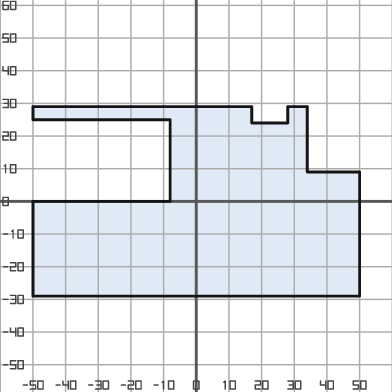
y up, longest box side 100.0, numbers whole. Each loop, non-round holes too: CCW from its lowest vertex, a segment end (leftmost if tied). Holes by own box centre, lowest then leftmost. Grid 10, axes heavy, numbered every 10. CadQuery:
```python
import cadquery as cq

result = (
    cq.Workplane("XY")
    .moveTo(-50.0, -29.0)
    .lineTo(50.0, -29.0)
    .lineTo(50.0, 9.0)
    .lineTo(34.0, 9.0)
    .lineTo(34.0, 29.0)
    .lineTo(28.0, 29.0)
    .lineTo(28.0, 24.0)
    .lineTo(17.0, 24.0)
    .lineTo(17.0, 29.0)
    .lineTo(-50.0, 29.0)
    .lineTo(-50.0, 25.0)
    .lineTo(-8.0, 25.0)
    .lineTo(-8.0, 0.0)
    .lineTo(-50.0, 0.0)
    .close()
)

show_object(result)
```